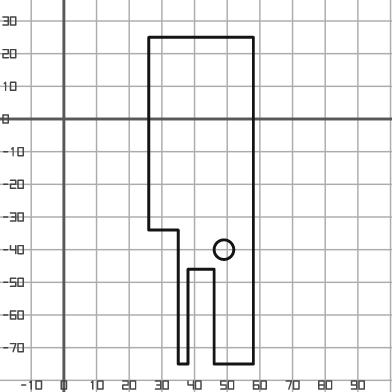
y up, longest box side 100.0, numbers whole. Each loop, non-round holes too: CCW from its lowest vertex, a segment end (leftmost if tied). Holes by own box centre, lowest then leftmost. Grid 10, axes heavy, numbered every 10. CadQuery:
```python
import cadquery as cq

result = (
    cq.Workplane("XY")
    .moveTo(35.0, -75.0)
    .lineTo(38.0, -75.0)
    .lineTo(38.0, -46.0)
    .lineTo(46.0, -46.0)
    .lineTo(46.0, -75.0)
    .lineTo(58.0, -75.0)
    .lineTo(58.0, 25.0)
    .lineTo(26.0, 25.0)
    .lineTo(26.0, -34.0)
    .lineTo(35.0, -34.0)
    .close()
    .moveTo(49.0, -40.0)
    .circle(3.0)
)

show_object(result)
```